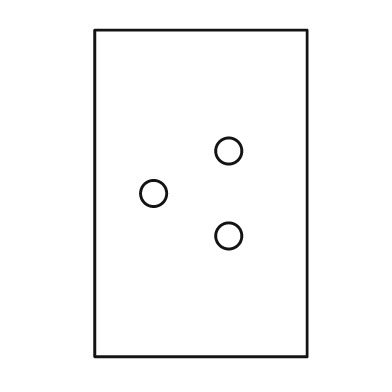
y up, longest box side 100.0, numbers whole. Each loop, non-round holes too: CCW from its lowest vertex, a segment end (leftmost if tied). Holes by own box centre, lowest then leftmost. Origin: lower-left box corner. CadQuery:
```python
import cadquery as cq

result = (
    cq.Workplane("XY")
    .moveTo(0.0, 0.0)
    .lineTo(65.0, 0.0)
    .lineTo(65.0, 100.0)
    .lineTo(0.0, 100.0)
    .close()
    .moveTo(41.0, 37.0)
    .circle(4.0)
    .moveTo(18.0, 50.0)
    .circle(4.0)
    .moveTo(41.0, 63.0)
    .circle(4.0)
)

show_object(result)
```